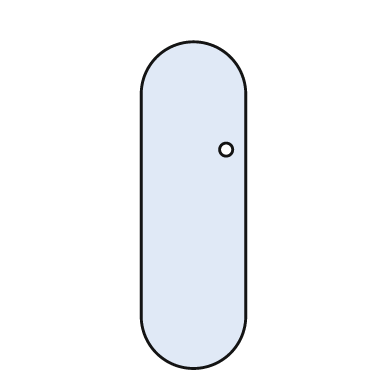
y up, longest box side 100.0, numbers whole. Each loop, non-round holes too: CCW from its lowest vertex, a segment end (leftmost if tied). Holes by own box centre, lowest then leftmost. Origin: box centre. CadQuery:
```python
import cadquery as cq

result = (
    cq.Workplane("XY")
    .moveTo(-16.0, -34.0)
    .threePointArc((0.0, -50.0), (16.0, -34.0))
    .lineTo(16.0, 34.0)
    .threePointArc((0.0, 50.0), (-16.0, 34.0))
    .close()
    .moveTo(10.0, 17.0)
    .circle(2.0)
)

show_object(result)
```